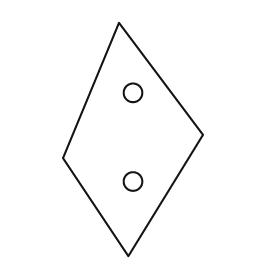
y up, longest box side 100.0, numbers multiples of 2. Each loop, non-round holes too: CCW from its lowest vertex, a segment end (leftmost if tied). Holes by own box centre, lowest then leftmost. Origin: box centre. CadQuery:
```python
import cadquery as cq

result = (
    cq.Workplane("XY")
    .moveTo(-2.0, -50.0)
    .lineTo(30.0, 2.0)
    .lineTo(-6.0, 50.0)
    .lineTo(-30.0, -8.0)
    .close()
    .moveTo(0.0, -18.0)
    .circle(4.0)
    .moveTo(0.0, 20.0)
    .circle(4.0)
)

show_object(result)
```